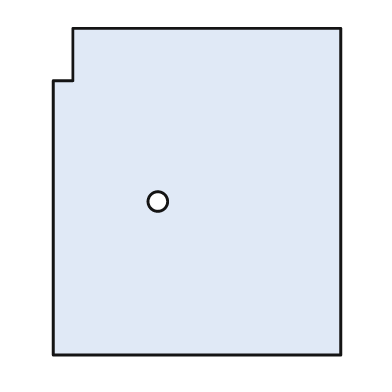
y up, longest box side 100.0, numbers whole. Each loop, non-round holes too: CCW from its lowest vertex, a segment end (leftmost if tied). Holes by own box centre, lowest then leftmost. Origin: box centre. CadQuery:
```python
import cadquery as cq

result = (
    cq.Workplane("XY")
    .moveTo(-44.0, -50.0)
    .lineTo(44.0, -50.0)
    .lineTo(44.0, 50.0)
    .lineTo(-38.0, 50.0)
    .lineTo(-38.0, 34.0)
    .lineTo(-44.0, 34.0)
    .close()
    .moveTo(-12.0, -3.0)
    .circle(3.0)
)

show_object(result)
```